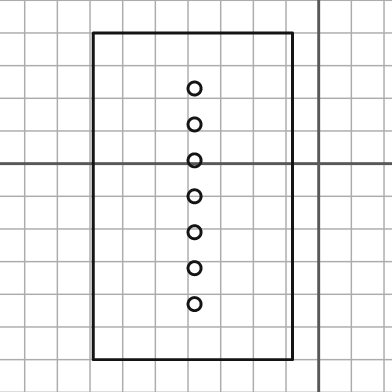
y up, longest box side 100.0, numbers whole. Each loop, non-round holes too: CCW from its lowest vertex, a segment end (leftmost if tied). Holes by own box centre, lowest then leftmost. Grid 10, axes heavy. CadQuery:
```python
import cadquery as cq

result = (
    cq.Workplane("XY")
    .moveTo(-69.0, -60.0)
    .lineTo(-8.0, -60.0)
    .lineTo(-8.0, 40.0)
    .lineTo(-69.0, 40.0)
    .close()
    .moveTo(-38.0, -43.0)
    .circle(2.0)
    .moveTo(-38.0, -32.0)
    .circle(2.0)
    .moveTo(-38.0, -21.0)
    .circle(2.0)
    .moveTo(-38.0, -10.0)
    .circle(2.0)
    .moveTo(-38.0, 1.0)
    .circle(2.0)
    .moveTo(-38.0, 12.0)
    .circle(2.0)
    .moveTo(-38.0, 23.0)
    .circle(2.0)
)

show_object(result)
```